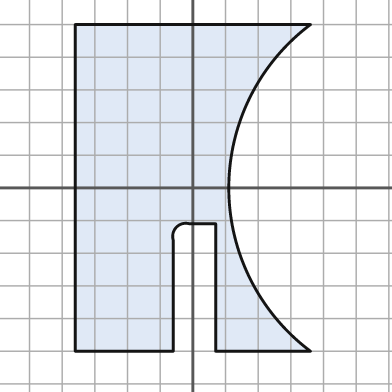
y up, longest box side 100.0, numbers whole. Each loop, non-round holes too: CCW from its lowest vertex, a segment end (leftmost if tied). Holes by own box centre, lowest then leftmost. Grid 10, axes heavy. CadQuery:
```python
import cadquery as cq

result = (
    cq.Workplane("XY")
    .moveTo(-36.0, -50.0)
    .lineTo(-6.0, -50.0)
    .lineTo(-6.0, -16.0)
    .threePointArc((-5.0, -12.0), (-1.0, -11.0))
    .lineTo(7.0, -11.0)
    .lineTo(7.0, -50.0)
    .lineTo(36.0, -50.0)
    .threePointArc((11.0, 0.0), (36.0, 50.0))
    .lineTo(-36.0, 50.0)
    .close()
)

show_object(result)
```